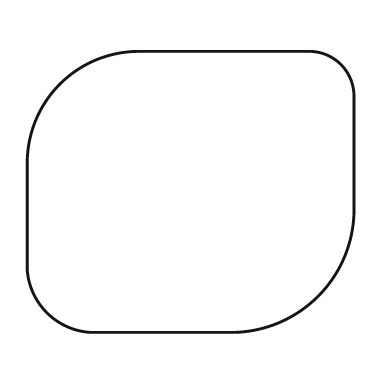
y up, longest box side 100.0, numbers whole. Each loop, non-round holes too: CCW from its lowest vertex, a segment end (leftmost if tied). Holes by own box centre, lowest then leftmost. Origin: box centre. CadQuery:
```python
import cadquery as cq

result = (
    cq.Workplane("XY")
    .moveTo(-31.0, -43.0)
    .lineTo(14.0, -43.0)
    .threePointArc((39.0, -32.0), (50.0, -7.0))
    .lineTo(50.0, 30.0)
    .threePointArc((46.0, 39.0), (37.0, 43.0))
    .lineTo(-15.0, 43.0)
    .threePointArc((-40.0, 33.0), (-50.0, 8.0))
    .lineTo(-50.0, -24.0)
    .threePointArc((-44.0, -37.0), (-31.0, -43.0))
    .close()
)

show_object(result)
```